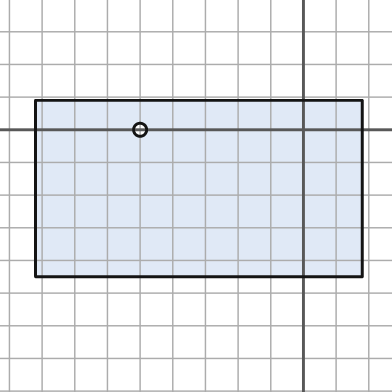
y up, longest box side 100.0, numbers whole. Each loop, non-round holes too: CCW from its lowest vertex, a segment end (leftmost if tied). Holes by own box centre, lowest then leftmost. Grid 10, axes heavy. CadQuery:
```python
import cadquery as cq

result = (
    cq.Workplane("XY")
    .moveTo(-82.0, -45.0)
    .lineTo(18.0, -45.0)
    .lineTo(18.0, 9.0)
    .lineTo(-82.0, 9.0)
    .close()
    .moveTo(-50.0, 0.0)
    .circle(2.0)
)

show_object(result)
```